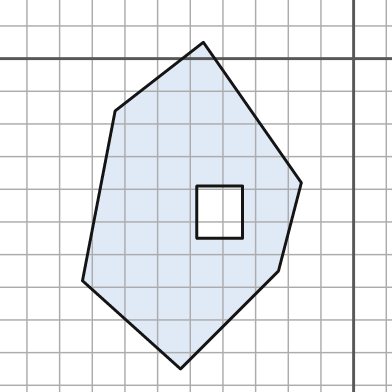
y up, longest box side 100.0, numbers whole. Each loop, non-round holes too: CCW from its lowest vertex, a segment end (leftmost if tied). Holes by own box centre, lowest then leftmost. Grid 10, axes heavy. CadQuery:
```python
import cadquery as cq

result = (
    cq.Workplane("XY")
    .moveTo(-53.0, -95.0)
    .lineTo(-23.0, -65.0)
    .lineTo(-16.0, -38.0)
    .lineTo(-46.0, 5.0)
    .lineTo(-73.0, -16.0)
    .lineTo(-83.0, -68.0)
    .close()
    .moveTo(-48.0, -55.0)
    .lineTo(-34.0, -55.0)
    .lineTo(-34.0, -39.0)
    .lineTo(-48.0, -39.0)
    .close()
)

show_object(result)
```